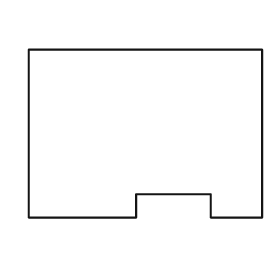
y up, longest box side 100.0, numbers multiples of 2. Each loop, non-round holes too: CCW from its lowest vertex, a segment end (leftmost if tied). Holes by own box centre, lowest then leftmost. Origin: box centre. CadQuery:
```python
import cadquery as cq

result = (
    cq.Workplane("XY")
    .moveTo(-50.0, -36.0)
    .lineTo(-4.0, -36.0)
    .lineTo(-4.0, -26.0)
    .lineTo(28.0, -26.0)
    .lineTo(28.0, -36.0)
    .lineTo(50.0, -36.0)
    .lineTo(50.0, 36.0)
    .lineTo(-50.0, 36.0)
    .close()
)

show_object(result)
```